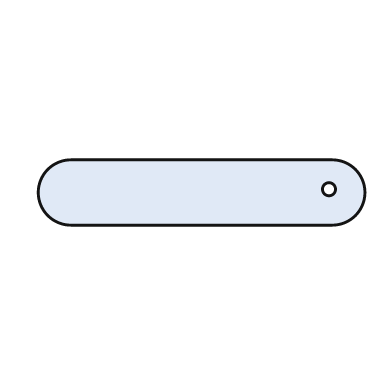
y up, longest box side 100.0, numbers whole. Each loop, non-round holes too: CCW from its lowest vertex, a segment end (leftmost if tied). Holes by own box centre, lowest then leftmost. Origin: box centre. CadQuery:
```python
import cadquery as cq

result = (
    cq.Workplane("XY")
    .moveTo(-40.0, -10.0)
    .lineTo(40.0, -10.0)
    .threePointArc((50.0, 0.0), (40.0, 10.0))
    .lineTo(-40.0, 10.0)
    .threePointArc((-50.0, 0.0), (-40.0, -10.0))
    .close()
    .moveTo(39.0, 1.0)
    .circle(2.0)
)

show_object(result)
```